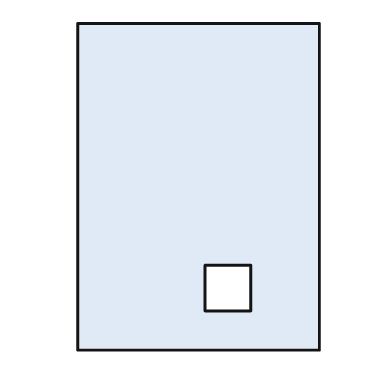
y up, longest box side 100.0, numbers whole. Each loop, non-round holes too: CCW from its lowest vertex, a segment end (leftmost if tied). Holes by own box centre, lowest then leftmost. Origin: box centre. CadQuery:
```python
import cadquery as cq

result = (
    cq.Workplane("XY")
    .moveTo(-37.0, -50.0)
    .lineTo(37.0, -50.0)
    .lineTo(37.0, 50.0)
    .lineTo(-37.0, 50.0)
    .close()
    .moveTo(2.0, -38.0)
    .lineTo(16.0, -38.0)
    .lineTo(16.0, -24.0)
    .lineTo(2.0, -24.0)
    .close()
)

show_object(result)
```